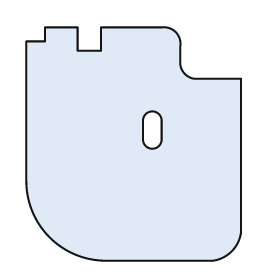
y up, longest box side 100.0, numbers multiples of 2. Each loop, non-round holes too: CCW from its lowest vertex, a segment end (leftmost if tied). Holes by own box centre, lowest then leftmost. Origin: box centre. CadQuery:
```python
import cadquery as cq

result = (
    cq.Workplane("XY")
    .moveTo(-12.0, -50.0)
    .lineTo(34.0, -50.0)
    .threePointArc((42.0, -46.0), (46.0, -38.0))
    .lineTo(46.0, 28.0)
    .lineTo(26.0, 28.0)
    .threePointArc((22.0, 30.0), (20.0, 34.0))
    .lineTo(20.0, 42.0)
    .threePointArc((18.0, 48.0), (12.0, 50.0))
    .lineTo(-14.0, 50.0)
    .lineTo(-14.0, 40.0)
    .lineTo(-24.0, 40.0)
    .lineTo(-24.0, 50.0)
    .lineTo(-38.0, 50.0)
    .lineTo(-38.0, 44.0)
    .lineTo(-46.0, 44.0)
    .lineTo(-46.0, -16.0)
    .threePointArc((-36.0, -40.0), (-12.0, -50.0))
    .close()
    .moveTo(4.0, 2.0)
    .threePointArc((8.0, -2.0), (12.0, 2.0))
    .lineTo(12.0, 10.0)
    .threePointArc((8.0, 14.0), (4.0, 10.0))
    .close()
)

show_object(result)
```